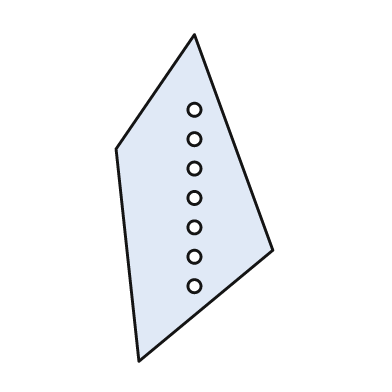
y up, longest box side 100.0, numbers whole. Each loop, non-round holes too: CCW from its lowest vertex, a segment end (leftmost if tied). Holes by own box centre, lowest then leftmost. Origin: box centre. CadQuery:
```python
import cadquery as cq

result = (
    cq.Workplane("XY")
    .moveTo(-17.0, -50.0)
    .lineTo(24.0, -16.0)
    .lineTo(0.0, 50.0)
    .lineTo(-24.0, 15.0)
    .close()
    .moveTo(0.0, -27.0)
    .circle(2.0)
    .moveTo(0.0, -18.0)
    .circle(2.0)
    .moveTo(0.0, -9.0)
    .circle(2.0)
    .moveTo(0.0, 0.0)
    .circle(2.0)
    .moveTo(0.0, 9.0)
    .circle(2.0)
    .moveTo(0.0, 18.0)
    .circle(2.0)
    .moveTo(0.0, 27.0)
    .circle(2.0)
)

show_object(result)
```